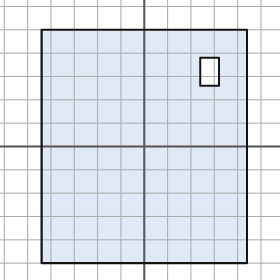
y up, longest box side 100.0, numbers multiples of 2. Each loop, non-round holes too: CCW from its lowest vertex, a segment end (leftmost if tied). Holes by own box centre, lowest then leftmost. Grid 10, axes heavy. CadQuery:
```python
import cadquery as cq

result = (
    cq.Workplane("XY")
    .moveTo(-44.0, -50.0)
    .lineTo(44.0, -50.0)
    .lineTo(44.0, 50.0)
    .lineTo(-44.0, 50.0)
    .close()
    .moveTo(24.0, 26.0)
    .lineTo(32.0, 26.0)
    .lineTo(32.0, 38.0)
    .lineTo(24.0, 38.0)
    .close()
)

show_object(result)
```